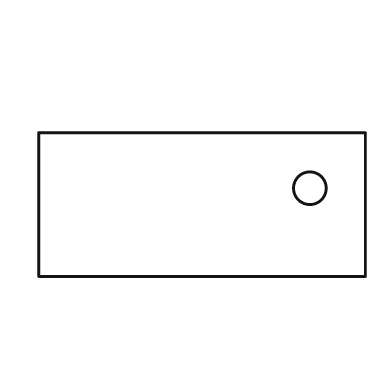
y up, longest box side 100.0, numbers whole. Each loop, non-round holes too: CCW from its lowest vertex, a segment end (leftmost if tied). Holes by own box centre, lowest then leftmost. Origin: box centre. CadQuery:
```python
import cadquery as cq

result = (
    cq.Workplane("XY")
    .moveTo(-50.0, -22.0)
    .lineTo(50.0, -22.0)
    .lineTo(50.0, 22.0)
    .lineTo(-50.0, 22.0)
    .close()
    .moveTo(33.0, 5.0)
    .circle(5.0)
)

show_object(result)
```